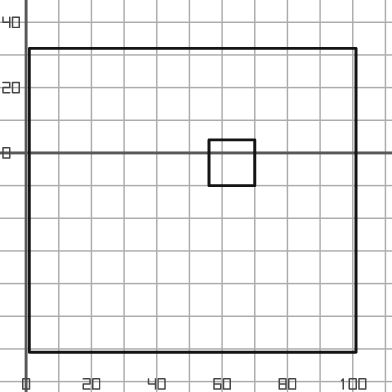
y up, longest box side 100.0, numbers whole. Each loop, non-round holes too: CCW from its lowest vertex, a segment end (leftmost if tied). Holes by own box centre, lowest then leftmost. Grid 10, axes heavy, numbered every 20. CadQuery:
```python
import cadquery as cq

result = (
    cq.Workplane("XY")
    .moveTo(1.0, -61.0)
    .lineTo(101.0, -61.0)
    .lineTo(101.0, 32.0)
    .lineTo(1.0, 32.0)
    .close()
    .moveTo(56.0, -10.0)
    .lineTo(70.0, -10.0)
    .lineTo(70.0, 4.0)
    .lineTo(56.0, 4.0)
    .close()
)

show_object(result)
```